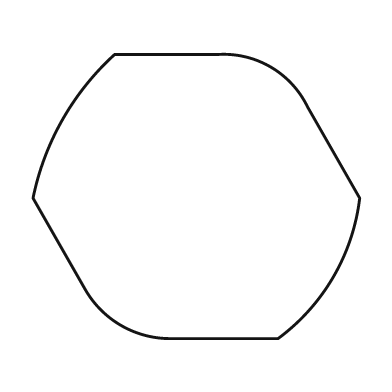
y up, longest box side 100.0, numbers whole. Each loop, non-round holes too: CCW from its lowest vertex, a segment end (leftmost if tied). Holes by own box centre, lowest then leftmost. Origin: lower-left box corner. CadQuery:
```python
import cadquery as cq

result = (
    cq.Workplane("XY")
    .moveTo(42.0, 0.0)
    .lineTo(75.0, 0.0)
    .threePointArc((92.0, 19.0), (100.0, 43.0))
    .lineTo(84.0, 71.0)
    .threePointArc((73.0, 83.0), (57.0, 87.0))
    .lineTo(25.0, 87.0)
    .threePointArc((9.0, 67.0), (0.0, 43.0))
    .lineTo(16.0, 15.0)
    .threePointArc((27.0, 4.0), (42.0, 0.0))
    .close()
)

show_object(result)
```